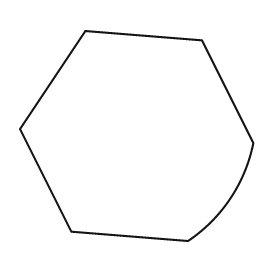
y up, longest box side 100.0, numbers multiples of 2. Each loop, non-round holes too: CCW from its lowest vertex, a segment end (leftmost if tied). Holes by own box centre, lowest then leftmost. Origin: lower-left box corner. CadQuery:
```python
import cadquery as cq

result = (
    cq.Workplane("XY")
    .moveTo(72.0, 0.0)
    .threePointArc((90.0, 18.0), (100.0, 42.0))
    .lineTo(78.0, 86.0)
    .lineTo(28.0, 90.0)
    .lineTo(0.0, 48.0)
    .lineTo(22.0, 4.0)
    .close()
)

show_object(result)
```